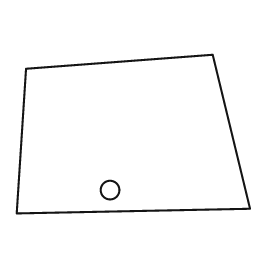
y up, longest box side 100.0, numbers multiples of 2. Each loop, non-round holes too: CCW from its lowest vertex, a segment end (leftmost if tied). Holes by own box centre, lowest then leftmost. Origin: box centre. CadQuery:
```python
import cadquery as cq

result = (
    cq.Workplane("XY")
    .moveTo(-50.0, -34.0)
    .lineTo(50.0, -32.0)
    .lineTo(34.0, 34.0)
    .lineTo(-46.0, 28.0)
    .close()
    .moveTo(-10.0, -24.0)
    .circle(4.0)
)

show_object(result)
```